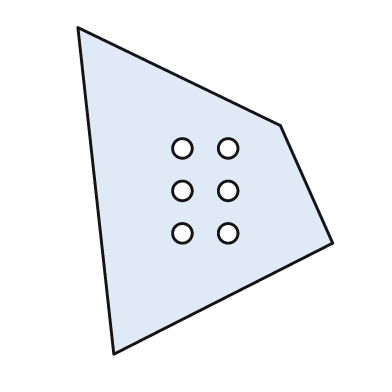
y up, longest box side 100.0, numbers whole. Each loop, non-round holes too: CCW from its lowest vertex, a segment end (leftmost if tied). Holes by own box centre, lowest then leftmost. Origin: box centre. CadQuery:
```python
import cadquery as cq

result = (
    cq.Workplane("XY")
    .moveTo(-28.0, -50.0)
    .lineTo(39.0, -16.0)
    .lineTo(23.0, 20.0)
    .lineTo(-39.0, 50.0)
    .close()
    .moveTo(-7.0, -13.0)
    .circle(3.0)
    .moveTo(7.0, -13.0)
    .circle(3.0)
    .moveTo(-7.0, 0.0)
    .circle(3.0)
    .moveTo(7.0, 0.0)
    .circle(3.0)
    .moveTo(-7.0, 13.0)
    .circle(3.0)
    .moveTo(7.0, 13.0)
    .circle(3.0)
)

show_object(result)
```